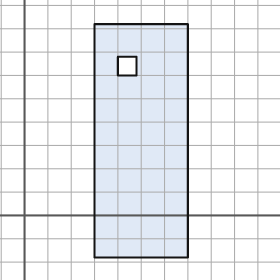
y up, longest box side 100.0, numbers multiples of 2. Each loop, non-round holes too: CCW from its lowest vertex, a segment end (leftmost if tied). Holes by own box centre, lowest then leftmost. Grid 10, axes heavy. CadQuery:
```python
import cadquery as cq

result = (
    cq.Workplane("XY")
    .moveTo(30.0, -18.0)
    .lineTo(70.0, -18.0)
    .lineTo(70.0, 82.0)
    .lineTo(30.0, 82.0)
    .close()
    .moveTo(40.0, 60.0)
    .lineTo(48.0, 60.0)
    .lineTo(48.0, 68.0)
    .lineTo(40.0, 68.0)
    .close()
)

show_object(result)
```